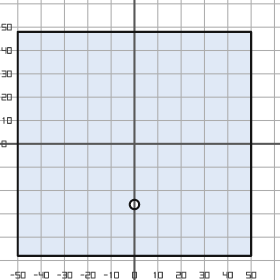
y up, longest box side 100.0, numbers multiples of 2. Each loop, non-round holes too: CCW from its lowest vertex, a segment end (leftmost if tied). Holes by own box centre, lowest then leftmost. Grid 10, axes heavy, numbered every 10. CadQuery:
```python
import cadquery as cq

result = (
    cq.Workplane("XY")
    .moveTo(-50.0, -48.0)
    .lineTo(50.0, -48.0)
    .lineTo(50.0, 48.0)
    .lineTo(-50.0, 48.0)
    .close()
    .moveTo(0.0, -26.0)
    .circle(2.0)
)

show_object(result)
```